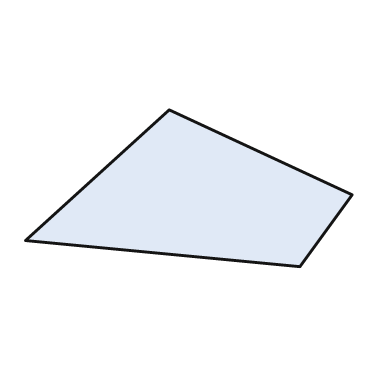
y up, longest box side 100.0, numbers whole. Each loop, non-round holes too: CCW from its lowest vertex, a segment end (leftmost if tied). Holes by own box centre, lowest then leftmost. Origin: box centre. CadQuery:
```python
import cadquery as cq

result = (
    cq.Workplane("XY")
    .moveTo(34.0, -24.0)
    .lineTo(50.0, -2.0)
    .lineTo(-6.0, 24.0)
    .lineTo(-50.0, -16.0)
    .close()
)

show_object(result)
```